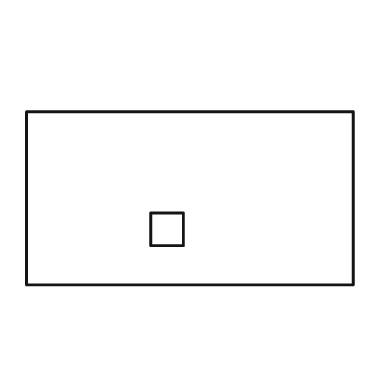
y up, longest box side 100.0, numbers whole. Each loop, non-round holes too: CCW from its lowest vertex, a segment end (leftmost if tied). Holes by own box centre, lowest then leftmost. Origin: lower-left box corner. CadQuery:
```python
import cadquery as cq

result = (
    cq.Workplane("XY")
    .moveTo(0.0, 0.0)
    .lineTo(100.0, 0.0)
    .lineTo(100.0, 53.0)
    .lineTo(0.0, 53.0)
    .close()
    .moveTo(38.0, 12.0)
    .lineTo(48.0, 12.0)
    .lineTo(48.0, 22.0)
    .lineTo(38.0, 22.0)
    .close()
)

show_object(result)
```